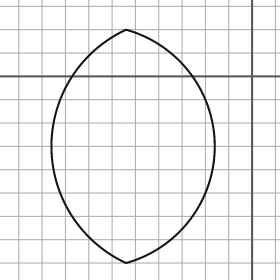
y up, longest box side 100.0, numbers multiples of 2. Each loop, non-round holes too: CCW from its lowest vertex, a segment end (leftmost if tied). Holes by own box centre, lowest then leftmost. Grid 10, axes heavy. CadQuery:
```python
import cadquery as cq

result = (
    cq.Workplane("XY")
    .moveTo(-54.0, -80.0)
    .threePointArc((-16.0, -30.0), (-54.0, 20.0))
    .threePointArc((-86.0, -30.0), (-54.0, -80.0))
    .close()
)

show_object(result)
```